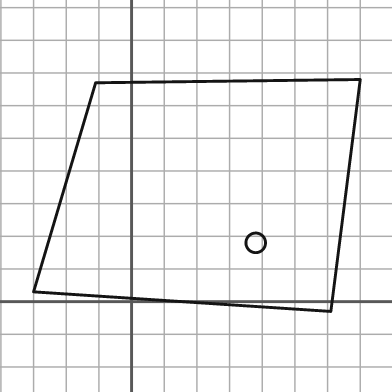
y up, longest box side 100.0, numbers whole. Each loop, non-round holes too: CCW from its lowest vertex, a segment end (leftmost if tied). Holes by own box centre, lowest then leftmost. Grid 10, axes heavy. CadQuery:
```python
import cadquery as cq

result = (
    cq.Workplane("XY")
    .moveTo(61.0, -3.0)
    .lineTo(70.0, 68.0)
    .lineTo(-11.0, 67.0)
    .lineTo(-30.0, 3.0)
    .close()
    .moveTo(38.0, 18.0)
    .circle(3.0)
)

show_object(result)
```